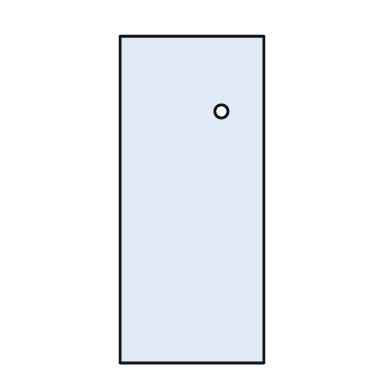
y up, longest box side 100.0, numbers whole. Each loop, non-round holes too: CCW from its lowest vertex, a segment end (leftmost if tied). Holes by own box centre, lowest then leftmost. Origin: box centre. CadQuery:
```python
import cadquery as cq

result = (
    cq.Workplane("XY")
    .moveTo(-22.0, -50.0)
    .lineTo(22.0, -50.0)
    .lineTo(22.0, 50.0)
    .lineTo(-22.0, 50.0)
    .close()
    .moveTo(9.0, 27.0)
    .circle(2.0)
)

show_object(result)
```